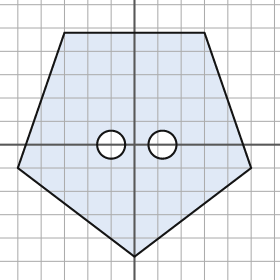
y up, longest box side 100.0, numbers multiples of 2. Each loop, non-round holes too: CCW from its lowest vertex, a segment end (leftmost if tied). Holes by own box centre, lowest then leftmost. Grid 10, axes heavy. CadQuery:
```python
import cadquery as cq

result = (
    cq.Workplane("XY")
    .moveTo(0.0, -48.0)
    .lineTo(50.0, -10.0)
    .lineTo(30.0, 48.0)
    .lineTo(-30.0, 48.0)
    .lineTo(-50.0, -10.0)
    .close()
    .moveTo(-10.0, 0.0)
    .circle(6.0)
    .moveTo(12.0, 0.0)
    .circle(6.0)
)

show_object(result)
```